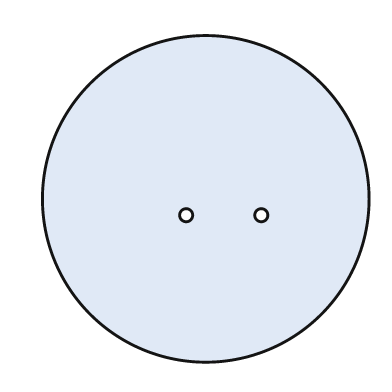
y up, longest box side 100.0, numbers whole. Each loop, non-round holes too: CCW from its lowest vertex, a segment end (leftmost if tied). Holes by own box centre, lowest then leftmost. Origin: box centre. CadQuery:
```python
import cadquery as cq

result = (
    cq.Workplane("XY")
    .moveTo(0.0, 0.0)
    .circle(50.0)
    .moveTo(-6.0, -5.0)
    .circle(2.0)
    .moveTo(17.0, -5.0)
    .circle(2.0)
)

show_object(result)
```